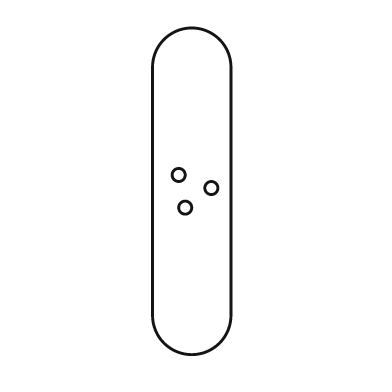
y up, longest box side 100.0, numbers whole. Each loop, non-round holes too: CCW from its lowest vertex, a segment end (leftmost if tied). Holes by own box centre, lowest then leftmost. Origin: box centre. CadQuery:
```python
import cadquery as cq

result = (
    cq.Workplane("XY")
    .moveTo(-12.0, -38.0)
    .threePointArc((0.0, -50.0), (12.0, -38.0))
    .lineTo(12.0, 38.0)
    .threePointArc((0.0, 50.0), (-12.0, 38.0))
    .close()
    .moveTo(-2.0, -5.0)
    .circle(2.0)
    .moveTo(6.0, 1.0)
    .circle(2.0)
    .moveTo(-4.0, 5.0)
    .circle(2.0)
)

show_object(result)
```